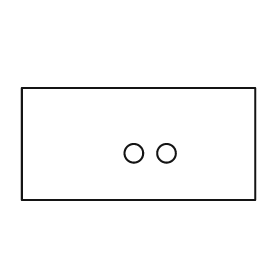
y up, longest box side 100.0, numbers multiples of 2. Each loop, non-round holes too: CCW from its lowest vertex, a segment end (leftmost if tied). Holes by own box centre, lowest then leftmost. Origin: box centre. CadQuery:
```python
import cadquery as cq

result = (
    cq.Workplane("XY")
    .moveTo(-50.0, -24.0)
    .lineTo(50.0, -24.0)
    .lineTo(50.0, 24.0)
    .lineTo(-50.0, 24.0)
    .close()
    .moveTo(-2.0, -4.0)
    .circle(4.0)
    .moveTo(12.0, -4.0)
    .circle(4.0)
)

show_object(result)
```